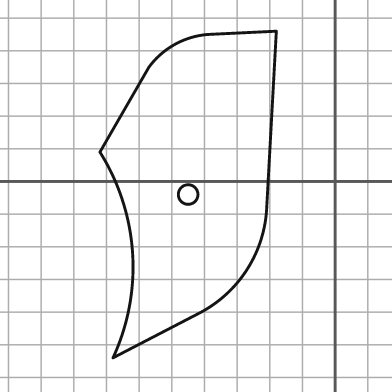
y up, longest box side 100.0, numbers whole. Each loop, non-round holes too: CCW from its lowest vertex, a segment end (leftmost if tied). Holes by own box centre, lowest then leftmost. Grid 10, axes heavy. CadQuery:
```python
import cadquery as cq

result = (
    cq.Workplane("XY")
    .moveTo(-68.0, -54.0)
    .lineTo(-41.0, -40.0)
    .threePointArc((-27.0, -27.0), (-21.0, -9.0))
    .lineTo(-18.0, 46.0)
    .lineTo(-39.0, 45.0)
    .threePointArc((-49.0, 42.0), (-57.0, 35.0))
    .lineTo(-72.0, 9.0)
    .threePointArc((-62.0, -22.0), (-68.0, -54.0))
    .close()
    .moveTo(-45.0, -4.0)
    .circle(3.0)
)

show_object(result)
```